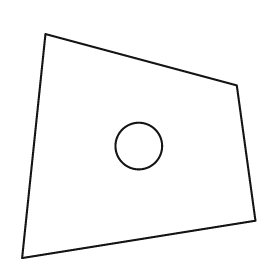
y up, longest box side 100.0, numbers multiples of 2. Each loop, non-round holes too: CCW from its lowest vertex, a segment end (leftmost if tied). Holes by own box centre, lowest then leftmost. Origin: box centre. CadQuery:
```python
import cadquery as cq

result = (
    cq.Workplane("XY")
    .moveTo(-50.0, -48.0)
    .lineTo(50.0, -32.0)
    .lineTo(42.0, 26.0)
    .lineTo(-40.0, 48.0)
    .close()
    .moveTo(0.0, 0.0)
    .circle(10.0)
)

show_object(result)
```